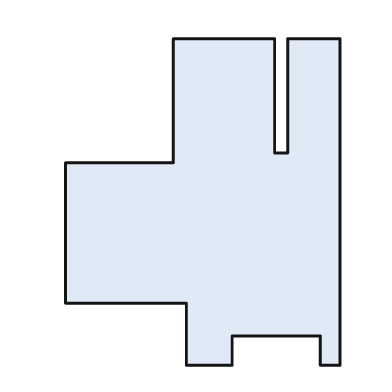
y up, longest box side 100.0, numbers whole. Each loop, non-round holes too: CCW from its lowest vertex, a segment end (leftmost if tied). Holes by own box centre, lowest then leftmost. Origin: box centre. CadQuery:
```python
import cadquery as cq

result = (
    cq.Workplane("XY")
    .moveTo(-5.0, -50.0)
    .lineTo(9.0, -50.0)
    .lineTo(9.0, -41.0)
    .lineTo(36.0, -41.0)
    .lineTo(36.0, -50.0)
    .lineTo(42.0, -50.0)
    .lineTo(42.0, 50.0)
    .lineTo(26.0, 50.0)
    .lineTo(26.0, 15.0)
    .lineTo(22.0, 15.0)
    .lineTo(22.0, 50.0)
    .lineTo(-9.0, 50.0)
    .lineTo(-9.0, 12.0)
    .lineTo(-42.0, 12.0)
    .lineTo(-42.0, -31.0)
    .lineTo(-5.0, -31.0)
    .close()
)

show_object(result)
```